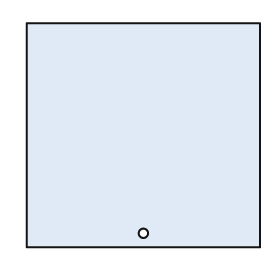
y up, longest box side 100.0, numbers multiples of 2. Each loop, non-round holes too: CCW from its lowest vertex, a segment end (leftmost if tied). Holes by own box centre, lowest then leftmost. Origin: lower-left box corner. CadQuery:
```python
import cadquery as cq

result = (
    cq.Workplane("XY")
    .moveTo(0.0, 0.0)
    .lineTo(100.0, 0.0)
    .lineTo(100.0, 96.0)
    .lineTo(0.0, 96.0)
    .close()
    .moveTo(50.0, 6.0)
    .circle(2.0)
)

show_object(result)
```